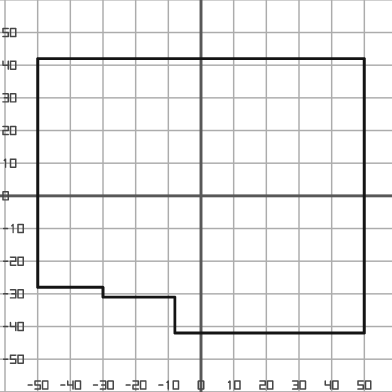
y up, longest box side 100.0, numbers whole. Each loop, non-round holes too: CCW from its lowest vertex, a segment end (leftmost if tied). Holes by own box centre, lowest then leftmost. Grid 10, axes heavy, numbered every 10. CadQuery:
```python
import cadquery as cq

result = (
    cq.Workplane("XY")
    .moveTo(-8.0, -42.0)
    .lineTo(50.0, -42.0)
    .lineTo(50.0, 42.0)
    .lineTo(-50.0, 42.0)
    .lineTo(-50.0, -28.0)
    .lineTo(-30.0, -28.0)
    .lineTo(-30.0, -31.0)
    .lineTo(-8.0, -31.0)
    .close()
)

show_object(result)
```